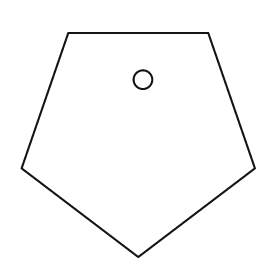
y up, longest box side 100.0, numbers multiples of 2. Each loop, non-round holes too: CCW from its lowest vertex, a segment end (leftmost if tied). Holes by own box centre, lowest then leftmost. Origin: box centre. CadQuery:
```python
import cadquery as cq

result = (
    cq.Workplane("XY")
    .moveTo(0.0, -48.0)
    .lineTo(50.0, -10.0)
    .lineTo(30.0, 48.0)
    .lineTo(-30.0, 48.0)
    .lineTo(-50.0, -10.0)
    .close()
    .moveTo(2.0, 28.0)
    .circle(4.0)
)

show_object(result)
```